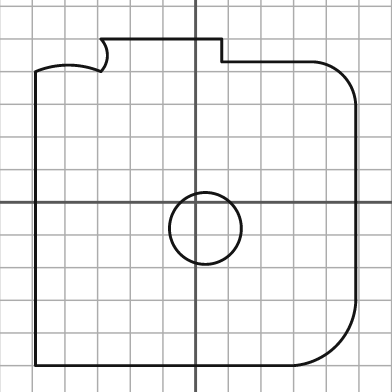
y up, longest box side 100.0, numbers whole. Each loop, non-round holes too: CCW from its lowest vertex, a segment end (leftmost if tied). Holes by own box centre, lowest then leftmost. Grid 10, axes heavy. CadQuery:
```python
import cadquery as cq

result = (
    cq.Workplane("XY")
    .moveTo(-49.0, -50.0)
    .lineTo(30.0, -50.0)
    .threePointArc((43.0, -44.0), (49.0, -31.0))
    .lineTo(49.0, 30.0)
    .threePointArc((45.0, 39.0), (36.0, 43.0))
    .lineTo(8.0, 43.0)
    .lineTo(8.0, 50.0)
    .lineTo(-29.0, 50.0)
    .threePointArc((-27.0, 45.0), (-29.0, 40.0))
    .threePointArc((-39.0, 42.0), (-49.0, 40.0))
    .close()
    .moveTo(3.0, -8.0)
    .circle(11.0)
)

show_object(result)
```